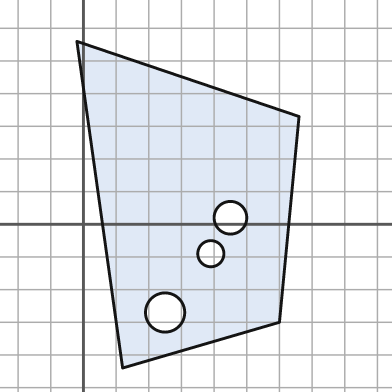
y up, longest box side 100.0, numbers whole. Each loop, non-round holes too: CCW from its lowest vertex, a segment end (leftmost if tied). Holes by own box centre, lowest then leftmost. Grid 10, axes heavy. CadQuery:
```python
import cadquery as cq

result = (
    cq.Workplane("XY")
    .moveTo(12.0, -44.0)
    .lineTo(60.0, -30.0)
    .lineTo(66.0, 33.0)
    .lineTo(-2.0, 56.0)
    .close()
    .moveTo(25.0, -27.0)
    .circle(6.0)
    .moveTo(39.0, -9.0)
    .circle(4.0)
    .moveTo(45.0, 2.0)
    .circle(5.0)
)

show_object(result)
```